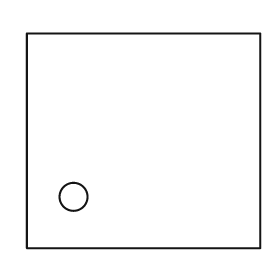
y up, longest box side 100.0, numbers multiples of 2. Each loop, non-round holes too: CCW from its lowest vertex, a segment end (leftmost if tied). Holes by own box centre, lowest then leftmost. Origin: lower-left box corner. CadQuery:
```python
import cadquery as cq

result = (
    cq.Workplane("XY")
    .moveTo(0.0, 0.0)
    .lineTo(100.0, 0.0)
    .lineTo(100.0, 92.0)
    .lineTo(0.0, 92.0)
    .close()
    .moveTo(20.0, 22.0)
    .circle(6.0)
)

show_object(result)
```